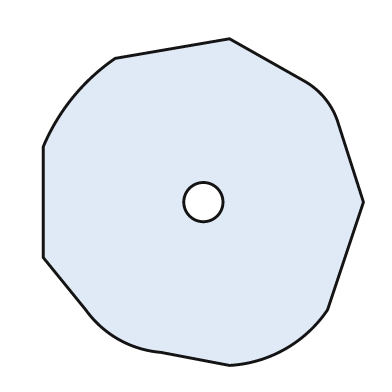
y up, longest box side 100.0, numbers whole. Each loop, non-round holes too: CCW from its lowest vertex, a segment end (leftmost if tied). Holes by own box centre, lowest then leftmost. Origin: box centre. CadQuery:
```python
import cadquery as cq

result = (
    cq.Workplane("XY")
    .moveTo(8.0, -50.0)
    .threePointArc((25.0, -45.0), (38.0, -33.0))
    .lineTo(49.0, 0.0)
    .lineTo(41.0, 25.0)
    .threePointArc((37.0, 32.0), (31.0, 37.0))
    .lineTo(8.0, 50.0)
    .lineTo(-27.0, 44.0)
    .threePointArc((-40.0, 32.0), (-49.0, 17.0))
    .lineTo(-49.0, -17.0)
    .lineTo(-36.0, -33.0)
    .threePointArc((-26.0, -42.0), (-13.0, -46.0))
    .close()
    .moveTo(0.0, 0.0)
    .circle(6.0)
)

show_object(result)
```